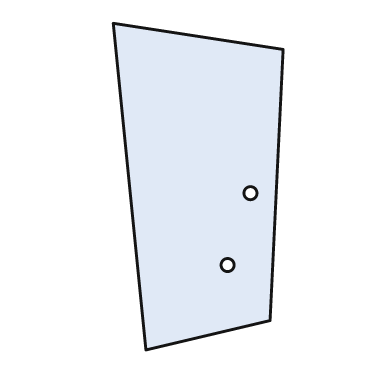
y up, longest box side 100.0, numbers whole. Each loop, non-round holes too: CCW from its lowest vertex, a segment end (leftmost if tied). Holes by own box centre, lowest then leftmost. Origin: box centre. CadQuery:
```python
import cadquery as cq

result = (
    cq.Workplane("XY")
    .moveTo(-16.0, -50.0)
    .lineTo(22.0, -41.0)
    .lineTo(26.0, 42.0)
    .lineTo(-26.0, 50.0)
    .close()
    .moveTo(9.0, -24.0)
    .circle(2.0)
    .moveTo(16.0, -2.0)
    .circle(2.0)
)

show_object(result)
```